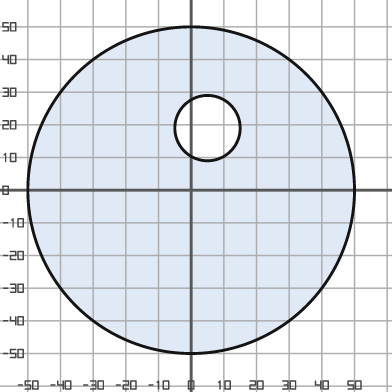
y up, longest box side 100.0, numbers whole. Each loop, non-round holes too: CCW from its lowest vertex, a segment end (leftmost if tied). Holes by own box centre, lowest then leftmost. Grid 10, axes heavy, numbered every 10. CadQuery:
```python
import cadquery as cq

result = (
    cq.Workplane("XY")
    .moveTo(0.0, 0.0)
    .circle(50.0)
    .moveTo(5.0, 19.0)
    .circle(10.0)
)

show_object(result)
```